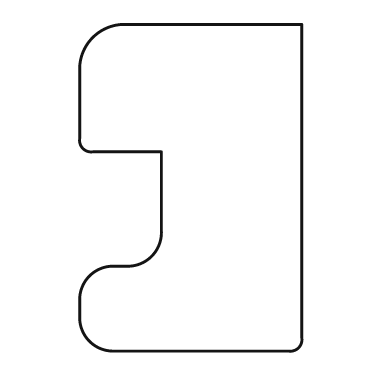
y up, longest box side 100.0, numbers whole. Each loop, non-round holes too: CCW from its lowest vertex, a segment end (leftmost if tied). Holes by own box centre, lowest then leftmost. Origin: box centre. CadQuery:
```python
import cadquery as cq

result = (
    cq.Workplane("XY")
    .moveTo(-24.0, -50.0)
    .lineTo(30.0, -50.0)
    .threePointArc((33.0, -49.0), (34.0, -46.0))
    .lineTo(34.0, 50.0)
    .lineTo(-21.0, 50.0)
    .threePointArc((-30.0, 46.0), (-34.0, 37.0))
    .lineTo(-34.0, 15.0)
    .threePointArc((-33.0, 12.0), (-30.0, 11.0))
    .lineTo(-9.0, 11.0)
    .lineTo(-9.0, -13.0)
    .threePointArc((-12.0, -21.0), (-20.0, -24.0))
    .lineTo(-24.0, -24.0)
    .threePointArc((-31.0, -27.0), (-34.0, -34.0))
    .lineTo(-34.0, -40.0)
    .threePointArc((-31.0, -47.0), (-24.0, -50.0))
    .close()
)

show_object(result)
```